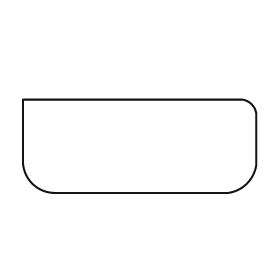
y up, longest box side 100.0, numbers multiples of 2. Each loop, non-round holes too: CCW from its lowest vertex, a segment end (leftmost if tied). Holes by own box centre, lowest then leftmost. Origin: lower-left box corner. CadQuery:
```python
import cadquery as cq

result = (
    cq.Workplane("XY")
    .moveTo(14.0, 0.0)
    .lineTo(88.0, 0.0)
    .threePointArc((96.0, 4.0), (100.0, 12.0))
    .lineTo(100.0, 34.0)
    .threePointArc((98.0, 38.0), (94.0, 40.0))
    .lineTo(0.0, 40.0)
    .lineTo(0.0, 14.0)
    .threePointArc((4.0, 4.0), (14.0, 0.0))
    .close()
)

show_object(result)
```